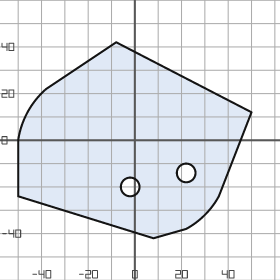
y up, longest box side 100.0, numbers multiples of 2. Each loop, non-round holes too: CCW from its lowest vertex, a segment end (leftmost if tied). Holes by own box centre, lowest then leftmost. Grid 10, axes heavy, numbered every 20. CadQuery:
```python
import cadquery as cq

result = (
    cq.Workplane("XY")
    .moveTo(8.0, -42.0)
    .lineTo(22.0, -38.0)
    .threePointArc((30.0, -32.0), (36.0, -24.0))
    .lineTo(50.0, 12.0)
    .lineTo(-8.0, 42.0)
    .lineTo(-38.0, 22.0)
    .threePointArc((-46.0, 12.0), (-50.0, 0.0))
    .lineTo(-50.0, -24.0)
    .close()
    .moveTo(-2.0, -20.0)
    .circle(4.0)
    .moveTo(22.0, -14.0)
    .circle(4.0)
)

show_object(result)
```